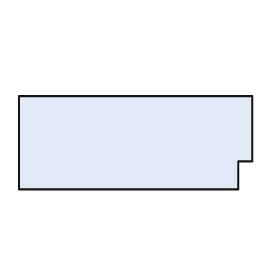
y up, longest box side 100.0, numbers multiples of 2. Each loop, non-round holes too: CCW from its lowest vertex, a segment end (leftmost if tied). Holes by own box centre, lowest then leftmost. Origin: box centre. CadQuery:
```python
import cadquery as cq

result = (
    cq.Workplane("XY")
    .moveTo(-50.0, -20.0)
    .lineTo(44.0, -20.0)
    .lineTo(44.0, -8.0)
    .lineTo(50.0, -8.0)
    .lineTo(50.0, 20.0)
    .lineTo(-50.0, 20.0)
    .close()
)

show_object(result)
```